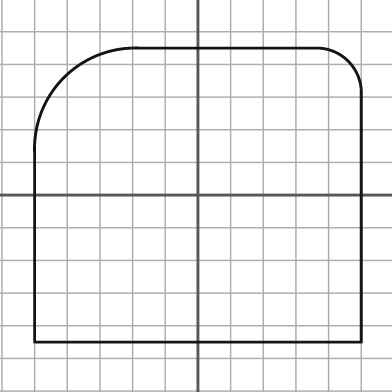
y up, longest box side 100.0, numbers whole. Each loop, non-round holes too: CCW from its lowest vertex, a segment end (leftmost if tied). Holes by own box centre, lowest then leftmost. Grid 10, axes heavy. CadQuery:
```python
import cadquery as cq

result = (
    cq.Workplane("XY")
    .moveTo(-50.0, -45.0)
    .lineTo(50.0, -45.0)
    .lineTo(50.0, 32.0)
    .threePointArc((46.0, 41.0), (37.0, 45.0))
    .lineTo(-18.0, 45.0)
    .threePointArc((-41.0, 36.0), (-50.0, 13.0))
    .close()
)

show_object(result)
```